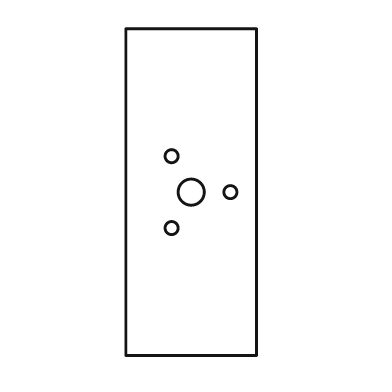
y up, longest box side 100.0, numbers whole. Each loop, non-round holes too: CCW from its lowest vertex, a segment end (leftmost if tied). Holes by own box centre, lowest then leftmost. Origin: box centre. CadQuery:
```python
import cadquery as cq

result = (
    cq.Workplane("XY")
    .moveTo(-20.0, -50.0)
    .lineTo(20.0, -50.0)
    .lineTo(20.0, 50.0)
    .lineTo(-20.0, 50.0)
    .close()
    .moveTo(-6.0, -11.0)
    .circle(2.0)
    .moveTo(0.0, 0.0)
    .circle(4.0)
    .moveTo(12.0, 0.0)
    .circle(2.0)
    .moveTo(-6.0, 11.0)
    .circle(2.0)
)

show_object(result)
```